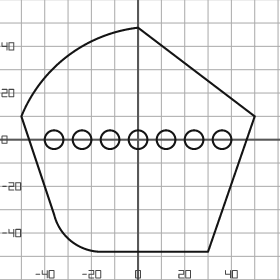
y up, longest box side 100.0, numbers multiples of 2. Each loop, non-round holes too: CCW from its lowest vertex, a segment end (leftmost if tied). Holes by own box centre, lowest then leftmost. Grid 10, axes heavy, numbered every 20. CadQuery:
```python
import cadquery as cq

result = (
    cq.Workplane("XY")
    .moveTo(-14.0, -48.0)
    .lineTo(30.0, -48.0)
    .lineTo(50.0, 10.0)
    .lineTo(0.0, 48.0)
    .threePointArc((-30.0, 36.0), (-50.0, 10.0))
    .lineTo(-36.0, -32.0)
    .threePointArc((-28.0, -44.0), (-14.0, -48.0))
    .close()
    .moveTo(-36.0, 0.0)
    .circle(4.0)
    .moveTo(-24.0, 0.0)
    .circle(4.0)
    .moveTo(-12.0, 0.0)
    .circle(4.0)
    .moveTo(0.0, 0.0)
    .circle(4.0)
    .moveTo(12.0, 0.0)
    .circle(4.0)
    .moveTo(24.0, 0.0)
    .circle(4.0)
    .moveTo(36.0, 0.0)
    .circle(4.0)
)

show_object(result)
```